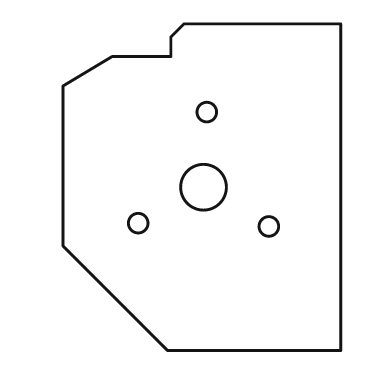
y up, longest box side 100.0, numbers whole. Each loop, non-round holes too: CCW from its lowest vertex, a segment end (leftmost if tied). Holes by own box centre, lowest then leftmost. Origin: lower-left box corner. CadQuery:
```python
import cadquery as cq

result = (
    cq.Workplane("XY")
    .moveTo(32.0, 0.0)
    .lineTo(85.0, 0.0)
    .lineTo(85.0, 100.0)
    .lineTo(37.0, 100.0)
    .lineTo(33.0, 96.0)
    .lineTo(33.0, 90.0)
    .lineTo(15.0, 90.0)
    .lineTo(0.0, 81.0)
    .lineTo(0.0, 32.0)
    .close()
    .moveTo(63.0, 38.0)
    .circle(3.0)
    .moveTo(23.0, 39.0)
    .circle(3.0)
    .moveTo(43.0, 50.0)
    .circle(7.0)
    .moveTo(44.0, 73.0)
    .circle(3.0)
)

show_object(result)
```